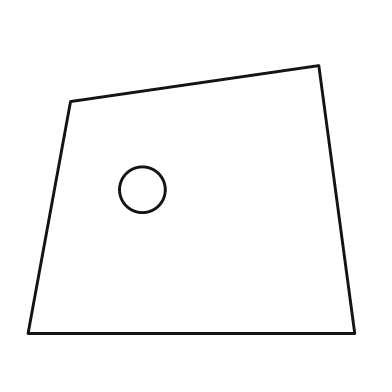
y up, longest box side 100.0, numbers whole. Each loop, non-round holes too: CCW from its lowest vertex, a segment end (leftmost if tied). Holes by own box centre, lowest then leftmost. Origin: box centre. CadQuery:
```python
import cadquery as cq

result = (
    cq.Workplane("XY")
    .moveTo(-50.0, -41.0)
    .lineTo(50.0, -41.0)
    .lineTo(39.0, 41.0)
    .lineTo(-37.0, 30.0)
    .close()
    .moveTo(-15.0, 3.0)
    .circle(7.0)
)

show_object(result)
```